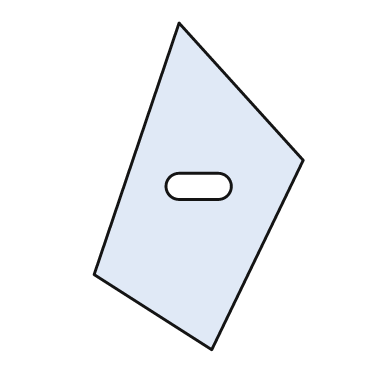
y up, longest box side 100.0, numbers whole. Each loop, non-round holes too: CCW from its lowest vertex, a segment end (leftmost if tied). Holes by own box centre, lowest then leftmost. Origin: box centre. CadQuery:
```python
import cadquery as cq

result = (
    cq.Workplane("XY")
    .moveTo(4.0, -50.0)
    .lineTo(32.0, 8.0)
    .lineTo(-6.0, 50.0)
    .lineTo(-32.0, -27.0)
    .close()
    .moveTo(-6.0, -4.0)
    .lineTo(6.0, -4.0)
    .threePointArc((10.0, 0.0), (6.0, 4.0))
    .lineTo(-6.0, 4.0)
    .threePointArc((-10.0, 0.0), (-6.0, -4.0))
    .close()
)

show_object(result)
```